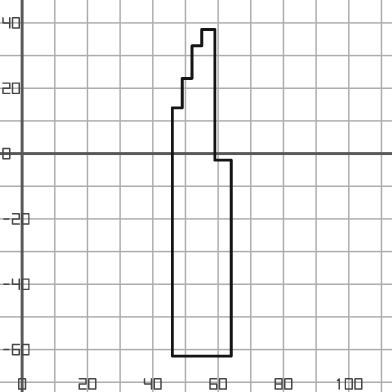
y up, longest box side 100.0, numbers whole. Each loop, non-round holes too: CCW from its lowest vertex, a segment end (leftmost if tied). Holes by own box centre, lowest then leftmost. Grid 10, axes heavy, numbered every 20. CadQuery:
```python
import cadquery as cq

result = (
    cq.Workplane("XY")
    .moveTo(46.0, -62.0)
    .lineTo(64.0, -62.0)
    .lineTo(64.0, -2.0)
    .lineTo(59.0, -2.0)
    .lineTo(59.0, 38.0)
    .lineTo(55.0, 38.0)
    .lineTo(55.0, 33.0)
    .lineTo(52.0, 33.0)
    .lineTo(52.0, 23.0)
    .lineTo(49.0, 23.0)
    .lineTo(49.0, 14.0)
    .lineTo(46.0, 14.0)
    .close()
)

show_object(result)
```